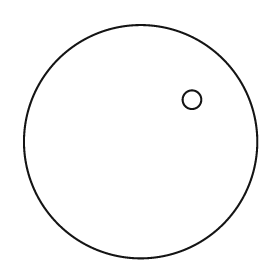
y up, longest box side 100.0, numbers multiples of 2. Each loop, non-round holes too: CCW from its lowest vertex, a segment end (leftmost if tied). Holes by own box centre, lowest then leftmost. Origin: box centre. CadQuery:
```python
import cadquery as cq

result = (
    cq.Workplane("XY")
    .moveTo(0.0, 0.0)
    .circle(50.0)
    .moveTo(22.0, 18.0)
    .circle(4.0)
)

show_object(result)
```